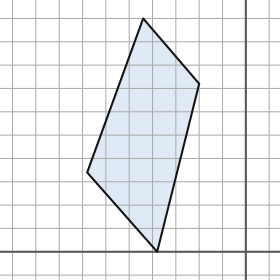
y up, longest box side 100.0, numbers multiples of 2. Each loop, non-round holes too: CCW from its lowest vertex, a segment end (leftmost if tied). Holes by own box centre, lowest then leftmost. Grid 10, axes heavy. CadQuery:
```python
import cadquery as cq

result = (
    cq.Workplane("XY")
    .moveTo(-38.0, 0.0)
    .lineTo(-20.0, 72.0)
    .lineTo(-44.0, 100.0)
    .lineTo(-68.0, 34.0)
    .close()
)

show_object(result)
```